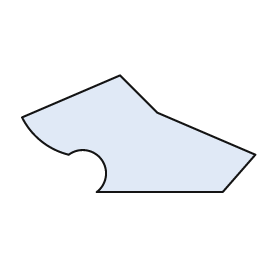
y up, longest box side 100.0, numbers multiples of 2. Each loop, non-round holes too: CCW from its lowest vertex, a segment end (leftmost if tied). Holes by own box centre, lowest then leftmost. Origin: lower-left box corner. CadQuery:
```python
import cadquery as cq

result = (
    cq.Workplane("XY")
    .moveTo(32.0, 0.0)
    .lineTo(86.0, 0.0)
    .lineTo(100.0, 16.0)
    .lineTo(58.0, 34.0)
    .lineTo(42.0, 50.0)
    .lineTo(0.0, 32.0)
    .threePointArc((8.0, 22.0), (20.0, 16.0))
    .threePointArc((34.0, 14.0), (32.0, 0.0))
    .close()
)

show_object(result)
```